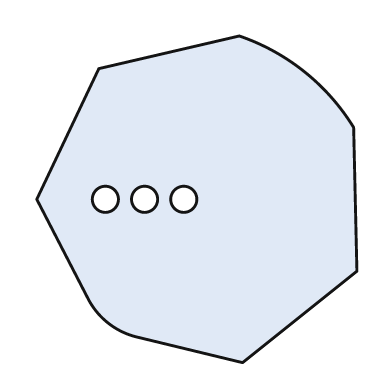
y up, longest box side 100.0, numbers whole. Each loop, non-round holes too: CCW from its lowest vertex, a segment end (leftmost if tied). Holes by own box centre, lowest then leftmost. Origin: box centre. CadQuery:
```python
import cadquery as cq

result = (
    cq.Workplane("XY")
    .moveTo(14.0, -50.0)
    .lineTo(49.0, -22.0)
    .lineTo(48.0, 22.0)
    .threePointArc((33.0, 39.0), (13.0, 50.0))
    .lineTo(-30.0, 40.0)
    .lineTo(-49.0, 0.0)
    .lineTo(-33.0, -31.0)
    .threePointArc((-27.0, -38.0), (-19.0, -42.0))
    .close()
    .moveTo(-28.0, 0.0)
    .circle(4.0)
    .moveTo(-16.0, 0.0)
    .circle(4.0)
    .moveTo(-4.0, 0.0)
    .circle(4.0)
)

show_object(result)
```